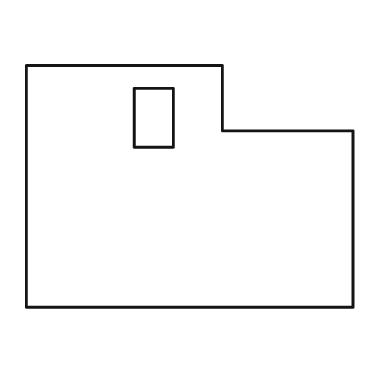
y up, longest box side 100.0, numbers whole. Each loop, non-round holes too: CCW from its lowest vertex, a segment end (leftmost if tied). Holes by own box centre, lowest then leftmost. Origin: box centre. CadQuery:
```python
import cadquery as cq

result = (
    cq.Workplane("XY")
    .moveTo(-50.0, -37.0)
    .lineTo(50.0, -37.0)
    .lineTo(50.0, 17.0)
    .lineTo(10.0, 17.0)
    .lineTo(10.0, 37.0)
    .lineTo(-50.0, 37.0)
    .close()
    .moveTo(-17.0, 12.0)
    .lineTo(-5.0, 12.0)
    .lineTo(-5.0, 30.0)
    .lineTo(-17.0, 30.0)
    .close()
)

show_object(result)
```